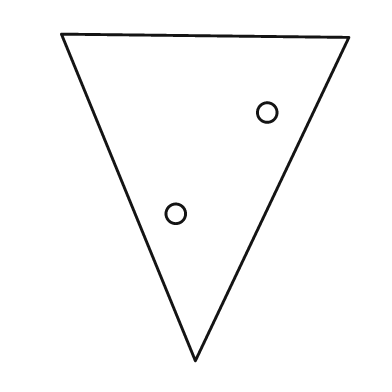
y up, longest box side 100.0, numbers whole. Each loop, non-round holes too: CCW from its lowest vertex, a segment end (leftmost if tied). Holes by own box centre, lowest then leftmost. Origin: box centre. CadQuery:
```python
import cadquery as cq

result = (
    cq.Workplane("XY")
    .moveTo(-3.0, -50.0)
    .lineTo(44.0, 49.0)
    .lineTo(-44.0, 50.0)
    .close()
    .moveTo(-9.0, -5.0)
    .circle(3.0)
    .moveTo(19.0, 26.0)
    .circle(3.0)
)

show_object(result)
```